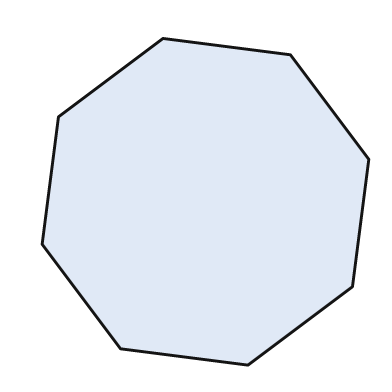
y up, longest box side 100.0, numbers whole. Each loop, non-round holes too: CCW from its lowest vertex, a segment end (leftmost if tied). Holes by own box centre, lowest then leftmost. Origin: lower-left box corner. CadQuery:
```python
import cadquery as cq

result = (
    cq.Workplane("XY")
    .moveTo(63.0, 0.0)
    .lineTo(95.0, 24.0)
    .lineTo(100.0, 63.0)
    .lineTo(76.0, 95.0)
    .lineTo(37.0, 100.0)
    .lineTo(5.0, 76.0)
    .lineTo(0.0, 37.0)
    .lineTo(24.0, 5.0)
    .close()
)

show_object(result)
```